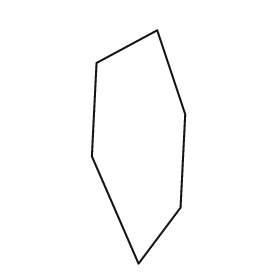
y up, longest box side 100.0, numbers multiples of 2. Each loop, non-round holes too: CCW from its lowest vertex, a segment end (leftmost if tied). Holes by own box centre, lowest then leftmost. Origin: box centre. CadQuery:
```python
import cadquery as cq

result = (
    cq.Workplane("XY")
    .moveTo(0.0, -50.0)
    .lineTo(18.0, -26.0)
    .lineTo(20.0, 14.0)
    .lineTo(8.0, 50.0)
    .lineTo(-18.0, 36.0)
    .lineTo(-20.0, -4.0)
    .close()
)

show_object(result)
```